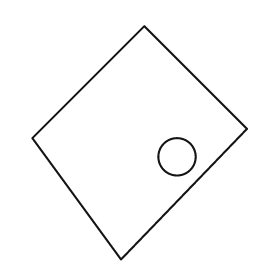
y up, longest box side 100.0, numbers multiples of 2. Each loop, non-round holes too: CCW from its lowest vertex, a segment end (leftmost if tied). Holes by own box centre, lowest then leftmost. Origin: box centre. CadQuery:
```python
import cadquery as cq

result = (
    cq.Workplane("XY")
    .moveTo(-8.0, -50.0)
    .lineTo(46.0, 6.0)
    .lineTo(2.0, 50.0)
    .lineTo(-46.0, 2.0)
    .close()
    .moveTo(16.0, -6.0)
    .circle(8.0)
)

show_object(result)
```